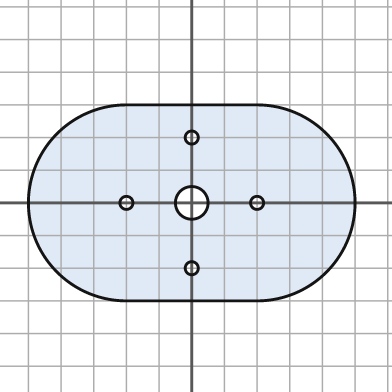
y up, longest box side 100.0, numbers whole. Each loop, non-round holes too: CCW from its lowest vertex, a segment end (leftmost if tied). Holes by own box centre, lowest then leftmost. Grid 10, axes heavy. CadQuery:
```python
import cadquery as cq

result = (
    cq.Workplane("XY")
    .moveTo(-20.0, -30.0)
    .lineTo(20.0, -30.0)
    .threePointArc((50.0, 0.0), (20.0, 30.0))
    .lineTo(-20.0, 30.0)
    .threePointArc((-50.0, 0.0), (-20.0, -30.0))
    .close()
    .moveTo(0.0, -20.0)
    .circle(2.0)
    .moveTo(-20.0, 0.0)
    .circle(2.0)
    .moveTo(0.0, 0.0)
    .circle(5.0)
    .moveTo(20.0, 0.0)
    .circle(2.0)
    .moveTo(0.0, 20.0)
    .circle(2.0)
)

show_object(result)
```